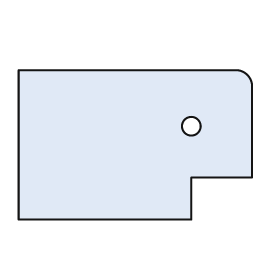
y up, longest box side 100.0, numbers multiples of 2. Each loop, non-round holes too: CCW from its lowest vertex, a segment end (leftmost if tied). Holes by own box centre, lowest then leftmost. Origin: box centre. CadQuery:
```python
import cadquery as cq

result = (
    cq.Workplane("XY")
    .moveTo(-50.0, -32.0)
    .lineTo(24.0, -32.0)
    .lineTo(24.0, -14.0)
    .lineTo(50.0, -14.0)
    .lineTo(50.0, 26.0)
    .threePointArc((48.0, 30.0), (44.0, 32.0))
    .lineTo(-50.0, 32.0)
    .close()
    .moveTo(24.0, 8.0)
    .circle(4.0)
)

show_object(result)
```